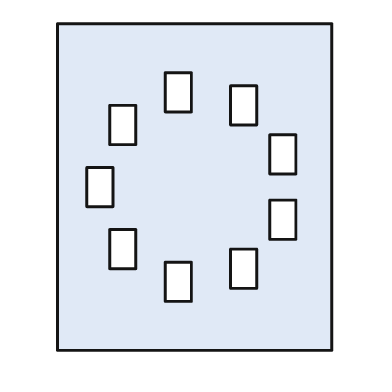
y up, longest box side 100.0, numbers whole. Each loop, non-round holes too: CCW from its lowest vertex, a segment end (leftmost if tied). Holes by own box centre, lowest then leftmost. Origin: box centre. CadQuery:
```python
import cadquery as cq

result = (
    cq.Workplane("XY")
    .moveTo(-42.0, -50.0)
    .lineTo(42.0, -50.0)
    .lineTo(42.0, 50.0)
    .lineTo(-42.0, 50.0)
    .close()
    .moveTo(-9.0, -35.0)
    .lineTo(-1.0, -35.0)
    .lineTo(-1.0, -23.0)
    .lineTo(-9.0, -23.0)
    .close()
    .moveTo(11.0, -31.0)
    .lineTo(19.0, -31.0)
    .lineTo(19.0, -19.0)
    .lineTo(11.0, -19.0)
    .close()
    .moveTo(-26.0, -25.0)
    .lineTo(-18.0, -25.0)
    .lineTo(-18.0, -13.0)
    .lineTo(-26.0, -13.0)
    .close()
    .moveTo(23.0, -16.0)
    .lineTo(31.0, -16.0)
    .lineTo(31.0, -4.0)
    .lineTo(23.0, -4.0)
    .close()
    .moveTo(-33.0, -6.0)
    .lineTo(-25.0, -6.0)
    .lineTo(-25.0, 6.0)
    .lineTo(-33.0, 6.0)
    .close()
    .moveTo(23.0, 4.0)
    .lineTo(31.0, 4.0)
    .lineTo(31.0, 16.0)
    .lineTo(23.0, 16.0)
    .close()
    .moveTo(-26.0, 13.0)
    .lineTo(-18.0, 13.0)
    .lineTo(-18.0, 25.0)
    .lineTo(-26.0, 25.0)
    .close()
    .moveTo(11.0, 19.0)
    .lineTo(19.0, 19.0)
    .lineTo(19.0, 31.0)
    .lineTo(11.0, 31.0)
    .close()
    .moveTo(-9.0, 23.0)
    .lineTo(-1.0, 23.0)
    .lineTo(-1.0, 35.0)
    .lineTo(-9.0, 35.0)
    .close()
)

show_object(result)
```